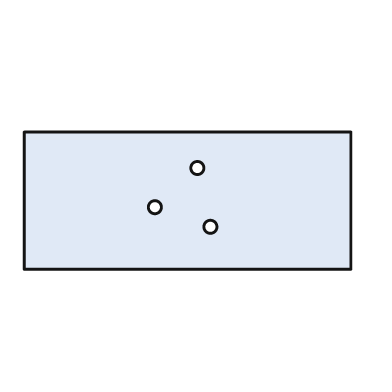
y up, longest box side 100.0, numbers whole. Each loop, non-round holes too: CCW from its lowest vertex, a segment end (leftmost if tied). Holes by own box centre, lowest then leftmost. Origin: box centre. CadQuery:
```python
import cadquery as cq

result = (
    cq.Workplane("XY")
    .moveTo(-50.0, -21.0)
    .lineTo(50.0, -21.0)
    .lineTo(50.0, 21.0)
    .lineTo(-50.0, 21.0)
    .close()
    .moveTo(7.0, -8.0)
    .circle(2.0)
    .moveTo(-10.0, -2.0)
    .circle(2.0)
    .moveTo(3.0, 10.0)
    .circle(2.0)
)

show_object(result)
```